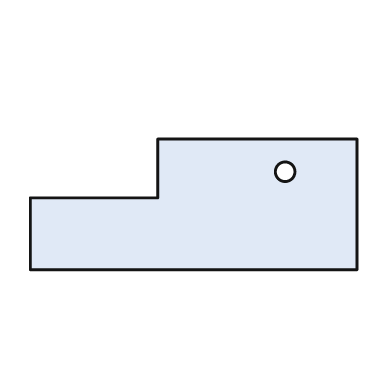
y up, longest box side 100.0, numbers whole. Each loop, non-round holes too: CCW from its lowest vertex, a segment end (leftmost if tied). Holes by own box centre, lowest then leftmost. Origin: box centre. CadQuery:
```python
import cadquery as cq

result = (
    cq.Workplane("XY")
    .moveTo(-50.0, -20.0)
    .lineTo(50.0, -20.0)
    .lineTo(50.0, 20.0)
    .lineTo(-11.0, 20.0)
    .lineTo(-11.0, 2.0)
    .lineTo(-50.0, 2.0)
    .close()
    .moveTo(28.0, 10.0)
    .circle(3.0)
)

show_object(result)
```